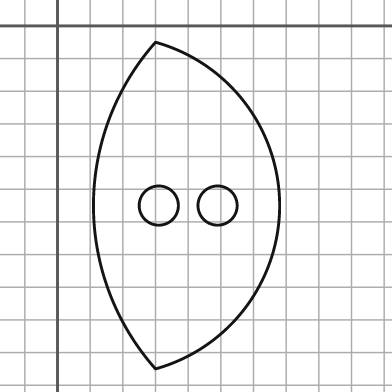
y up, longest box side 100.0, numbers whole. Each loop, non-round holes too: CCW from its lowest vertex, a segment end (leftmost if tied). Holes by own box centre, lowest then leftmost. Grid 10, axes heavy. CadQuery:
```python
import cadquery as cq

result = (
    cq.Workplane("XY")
    .moveTo(30.0, -105.0)
    .threePointArc((68.0, -55.0), (30.0, -5.0))
    .threePointArc((11.0, -55.0), (30.0, -105.0))
    .close()
    .moveTo(31.0, -55.0)
    .circle(6.0)
    .moveTo(49.0, -55.0)
    .circle(6.0)
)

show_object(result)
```